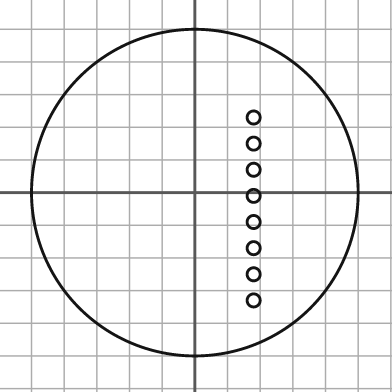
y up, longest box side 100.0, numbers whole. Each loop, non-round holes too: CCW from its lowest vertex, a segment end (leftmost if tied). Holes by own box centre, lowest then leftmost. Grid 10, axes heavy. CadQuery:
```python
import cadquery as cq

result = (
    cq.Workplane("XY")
    .moveTo(0.0, 0.0)
    .circle(50.0)
    .moveTo(18.0, -33.0)
    .circle(2.0)
    .moveTo(18.0, -25.0)
    .circle(2.0)
    .moveTo(18.0, -17.0)
    .circle(2.0)
    .moveTo(18.0, -9.0)
    .circle(2.0)
    .moveTo(18.0, -1.0)
    .circle(2.0)
    .moveTo(18.0, 7.0)
    .circle(2.0)
    .moveTo(18.0, 15.0)
    .circle(2.0)
    .moveTo(18.0, 23.0)
    .circle(2.0)
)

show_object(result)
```